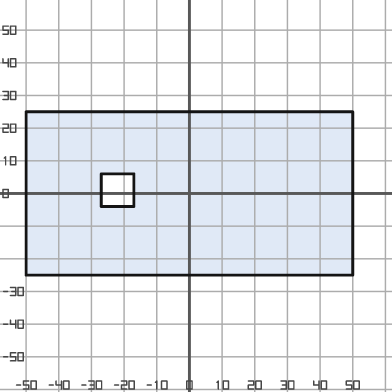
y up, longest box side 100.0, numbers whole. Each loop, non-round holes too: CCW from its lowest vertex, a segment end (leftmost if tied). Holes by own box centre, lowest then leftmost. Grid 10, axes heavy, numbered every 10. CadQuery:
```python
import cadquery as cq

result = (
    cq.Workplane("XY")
    .moveTo(-50.0, -25.0)
    .lineTo(50.0, -25.0)
    .lineTo(50.0, 25.0)
    .lineTo(-50.0, 25.0)
    .close()
    .moveTo(-27.0, -4.0)
    .lineTo(-17.0, -4.0)
    .lineTo(-17.0, 6.0)
    .lineTo(-27.0, 6.0)
    .close()
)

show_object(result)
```